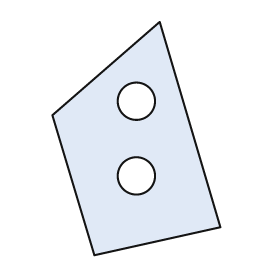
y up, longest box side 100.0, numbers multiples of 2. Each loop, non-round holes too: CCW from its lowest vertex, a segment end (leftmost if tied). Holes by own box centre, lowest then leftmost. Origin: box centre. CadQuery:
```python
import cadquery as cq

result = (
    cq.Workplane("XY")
    .moveTo(-18.0, -50.0)
    .lineTo(36.0, -38.0)
    .lineTo(10.0, 50.0)
    .lineTo(-36.0, 10.0)
    .close()
    .moveTo(0.0, -16.0)
    .circle(8.0)
    .moveTo(0.0, 16.0)
    .circle(8.0)
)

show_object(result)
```